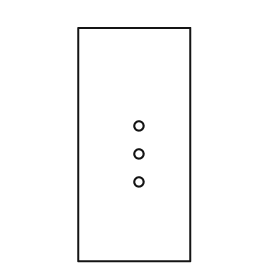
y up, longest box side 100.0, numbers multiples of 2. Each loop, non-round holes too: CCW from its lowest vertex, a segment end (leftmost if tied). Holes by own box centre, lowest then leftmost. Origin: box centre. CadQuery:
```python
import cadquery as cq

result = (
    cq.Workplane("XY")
    .moveTo(-24.0, -50.0)
    .lineTo(24.0, -50.0)
    .lineTo(24.0, 50.0)
    .lineTo(-24.0, 50.0)
    .close()
    .moveTo(2.0, -16.0)
    .circle(2.0)
    .moveTo(2.0, -4.0)
    .circle(2.0)
    .moveTo(2.0, 8.0)
    .circle(2.0)
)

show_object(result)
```